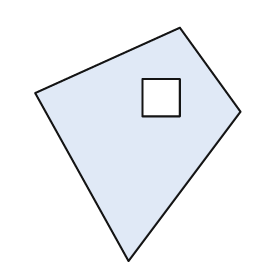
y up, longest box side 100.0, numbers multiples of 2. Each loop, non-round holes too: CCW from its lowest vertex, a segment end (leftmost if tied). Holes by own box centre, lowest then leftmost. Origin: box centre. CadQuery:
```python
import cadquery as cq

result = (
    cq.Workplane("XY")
    .moveTo(-4.0, -50.0)
    .lineTo(44.0, 14.0)
    .lineTo(18.0, 50.0)
    .lineTo(-44.0, 22.0)
    .close()
    .moveTo(2.0, 12.0)
    .lineTo(18.0, 12.0)
    .lineTo(18.0, 28.0)
    .lineTo(2.0, 28.0)
    .close()
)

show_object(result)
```